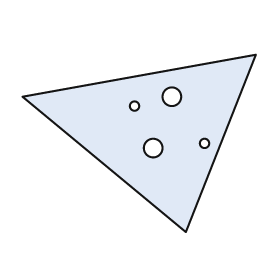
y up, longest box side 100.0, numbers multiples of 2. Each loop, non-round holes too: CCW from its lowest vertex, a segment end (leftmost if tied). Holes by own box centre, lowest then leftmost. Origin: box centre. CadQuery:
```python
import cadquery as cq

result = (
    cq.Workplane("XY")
    .moveTo(20.0, -38.0)
    .lineTo(50.0, 38.0)
    .lineTo(-50.0, 20.0)
    .close()
    .moveTo(6.0, -2.0)
    .circle(4.0)
    .moveTo(28.0, 0.0)
    .circle(2.0)
    .moveTo(-2.0, 16.0)
    .circle(2.0)
    .moveTo(14.0, 20.0)
    .circle(4.0)
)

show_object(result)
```